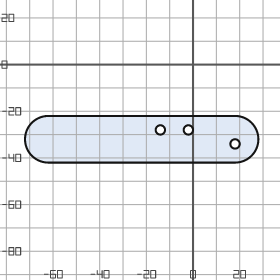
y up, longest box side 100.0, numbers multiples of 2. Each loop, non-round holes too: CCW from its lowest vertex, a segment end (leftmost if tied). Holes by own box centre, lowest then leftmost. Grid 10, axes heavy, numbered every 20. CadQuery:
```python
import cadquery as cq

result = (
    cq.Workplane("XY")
    .moveTo(-62.0, -42.0)
    .lineTo(18.0, -42.0)
    .threePointArc((28.0, -32.0), (18.0, -22.0))
    .lineTo(-62.0, -22.0)
    .threePointArc((-72.0, -32.0), (-62.0, -42.0))
    .close()
    .moveTo(18.0, -34.0)
    .circle(2.0)
    .moveTo(-14.0, -28.0)
    .circle(2.0)
    .moveTo(-2.0, -28.0)
    .circle(2.0)
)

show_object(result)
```